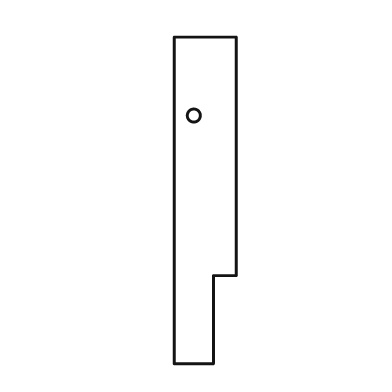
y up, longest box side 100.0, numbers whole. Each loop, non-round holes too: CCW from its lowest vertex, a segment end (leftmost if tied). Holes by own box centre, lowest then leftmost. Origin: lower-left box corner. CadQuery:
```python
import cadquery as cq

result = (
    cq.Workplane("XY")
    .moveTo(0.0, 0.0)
    .lineTo(12.0, 0.0)
    .lineTo(12.0, 27.0)
    .lineTo(19.0, 27.0)
    .lineTo(19.0, 100.0)
    .lineTo(0.0, 100.0)
    .close()
    .moveTo(6.0, 76.0)
    .circle(2.0)
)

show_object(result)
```